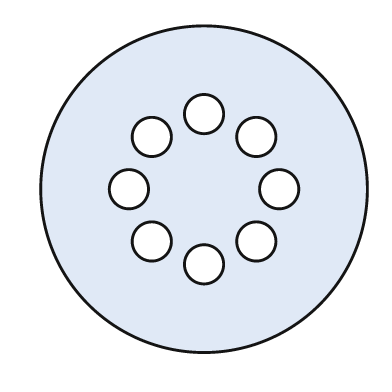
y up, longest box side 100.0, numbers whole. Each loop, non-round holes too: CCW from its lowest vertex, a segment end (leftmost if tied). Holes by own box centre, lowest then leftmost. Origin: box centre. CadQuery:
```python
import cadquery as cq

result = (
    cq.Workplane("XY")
    .moveTo(0.0, 0.0)
    .circle(50.0)
    .moveTo(0.0, -23.0)
    .circle(6.0)
    .moveTo(-16.0, -16.0)
    .circle(6.0)
    .moveTo(16.0, -16.0)
    .circle(6.0)
    .moveTo(-23.0, 0.0)
    .circle(6.0)
    .moveTo(23.0, 0.0)
    .circle(6.0)
    .moveTo(-16.0, 16.0)
    .circle(6.0)
    .moveTo(16.0, 16.0)
    .circle(6.0)
    .moveTo(0.0, 23.0)
    .circle(6.0)
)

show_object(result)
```